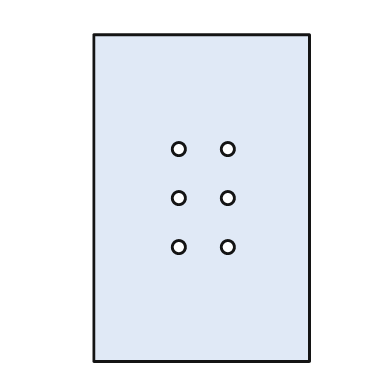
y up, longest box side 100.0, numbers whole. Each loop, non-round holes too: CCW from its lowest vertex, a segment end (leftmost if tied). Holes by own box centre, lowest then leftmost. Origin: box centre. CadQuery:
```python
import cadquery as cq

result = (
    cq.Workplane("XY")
    .moveTo(-33.0, -50.0)
    .lineTo(33.0, -50.0)
    .lineTo(33.0, 50.0)
    .lineTo(-33.0, 50.0)
    .close()
    .moveTo(-7.0, -15.0)
    .circle(2.0)
    .moveTo(8.0, -15.0)
    .circle(2.0)
    .moveTo(-7.0, 0.0)
    .circle(2.0)
    .moveTo(8.0, 0.0)
    .circle(2.0)
    .moveTo(-7.0, 15.0)
    .circle(2.0)
    .moveTo(8.0, 15.0)
    .circle(2.0)
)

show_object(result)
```